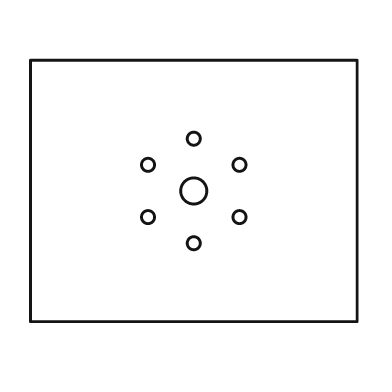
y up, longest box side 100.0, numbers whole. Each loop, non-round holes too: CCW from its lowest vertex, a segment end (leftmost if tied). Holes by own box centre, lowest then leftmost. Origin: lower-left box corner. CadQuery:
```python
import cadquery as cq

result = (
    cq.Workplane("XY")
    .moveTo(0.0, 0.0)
    .lineTo(100.0, 0.0)
    .lineTo(100.0, 80.0)
    .lineTo(0.0, 80.0)
    .close()
    .moveTo(50.0, 24.0)
    .circle(2.0)
    .moveTo(36.0, 32.0)
    .circle(2.0)
    .moveTo(64.0, 32.0)
    .circle(2.0)
    .moveTo(50.0, 40.0)
    .circle(4.0)
    .moveTo(36.0, 48.0)
    .circle(2.0)
    .moveTo(64.0, 48.0)
    .circle(2.0)
    .moveTo(50.0, 56.0)
    .circle(2.0)
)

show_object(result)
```